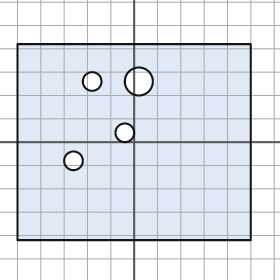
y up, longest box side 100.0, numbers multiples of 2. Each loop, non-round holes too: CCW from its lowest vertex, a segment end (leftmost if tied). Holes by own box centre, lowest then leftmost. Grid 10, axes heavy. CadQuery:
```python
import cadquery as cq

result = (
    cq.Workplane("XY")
    .moveTo(-50.0, -42.0)
    .lineTo(50.0, -42.0)
    .lineTo(50.0, 42.0)
    .lineTo(-50.0, 42.0)
    .close()
    .moveTo(-26.0, -8.0)
    .circle(4.0)
    .moveTo(-4.0, 4.0)
    .circle(4.0)
    .moveTo(-18.0, 26.0)
    .circle(4.0)
    .moveTo(2.0, 26.0)
    .circle(6.0)
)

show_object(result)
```